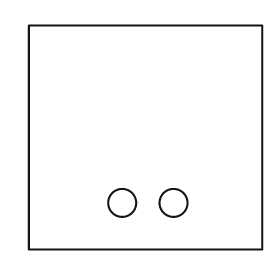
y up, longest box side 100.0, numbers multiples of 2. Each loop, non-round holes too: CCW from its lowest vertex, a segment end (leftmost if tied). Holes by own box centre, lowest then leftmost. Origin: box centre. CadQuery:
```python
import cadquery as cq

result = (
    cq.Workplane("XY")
    .moveTo(-50.0, -48.0)
    .lineTo(50.0, -48.0)
    .lineTo(50.0, 48.0)
    .lineTo(-50.0, 48.0)
    .close()
    .moveTo(-10.0, -28.0)
    .circle(6.0)
    .moveTo(12.0, -28.0)
    .circle(6.0)
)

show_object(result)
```